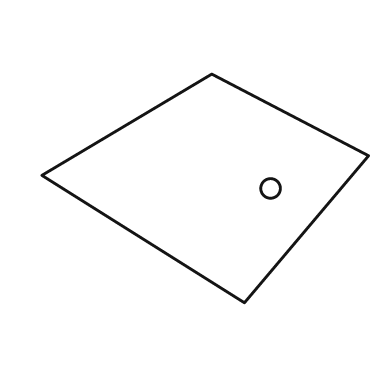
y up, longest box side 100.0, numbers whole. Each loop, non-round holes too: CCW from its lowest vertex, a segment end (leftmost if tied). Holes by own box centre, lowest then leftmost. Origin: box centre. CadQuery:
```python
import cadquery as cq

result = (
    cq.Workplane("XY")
    .moveTo(12.0, -35.0)
    .lineTo(50.0, 10.0)
    .lineTo(2.0, 35.0)
    .lineTo(-50.0, 4.0)
    .close()
    .moveTo(20.0, 0.0)
    .circle(3.0)
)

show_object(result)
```